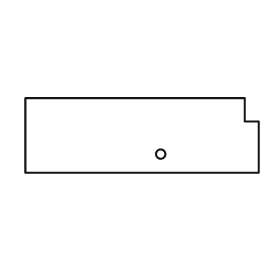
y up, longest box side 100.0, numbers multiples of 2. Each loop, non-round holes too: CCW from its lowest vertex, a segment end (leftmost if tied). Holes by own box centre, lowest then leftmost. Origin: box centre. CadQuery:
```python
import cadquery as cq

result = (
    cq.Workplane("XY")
    .moveTo(-50.0, -16.0)
    .lineTo(50.0, -16.0)
    .lineTo(50.0, 6.0)
    .lineTo(44.0, 6.0)
    .lineTo(44.0, 16.0)
    .lineTo(-50.0, 16.0)
    .close()
    .moveTo(8.0, -8.0)
    .circle(2.0)
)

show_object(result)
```